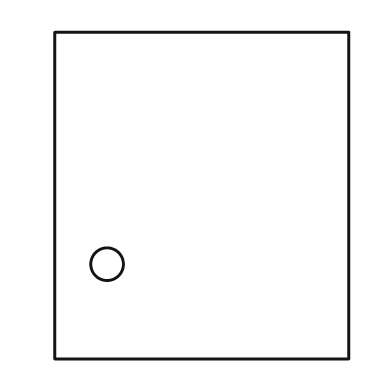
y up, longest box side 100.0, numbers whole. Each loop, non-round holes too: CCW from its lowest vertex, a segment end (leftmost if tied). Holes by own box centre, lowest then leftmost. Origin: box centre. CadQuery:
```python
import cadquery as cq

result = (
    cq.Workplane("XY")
    .moveTo(-45.0, -50.0)
    .lineTo(45.0, -50.0)
    .lineTo(45.0, 50.0)
    .lineTo(-45.0, 50.0)
    .close()
    .moveTo(-29.0, -21.0)
    .circle(5.0)
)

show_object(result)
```